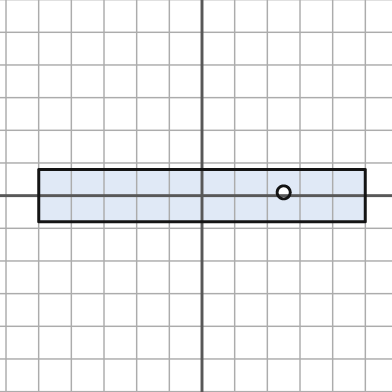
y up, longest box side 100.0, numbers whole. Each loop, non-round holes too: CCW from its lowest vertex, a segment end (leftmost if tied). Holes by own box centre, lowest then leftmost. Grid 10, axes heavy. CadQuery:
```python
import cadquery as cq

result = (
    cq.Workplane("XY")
    .moveTo(-50.0, -8.0)
    .lineTo(50.0, -8.0)
    .lineTo(50.0, 8.0)
    .lineTo(-50.0, 8.0)
    .close()
    .moveTo(25.0, 1.0)
    .circle(2.0)
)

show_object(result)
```